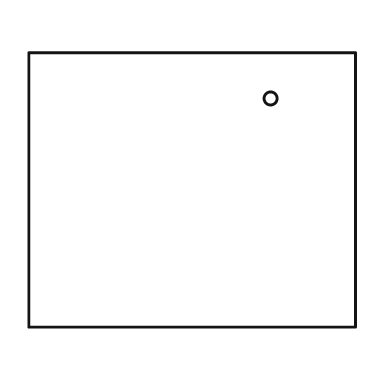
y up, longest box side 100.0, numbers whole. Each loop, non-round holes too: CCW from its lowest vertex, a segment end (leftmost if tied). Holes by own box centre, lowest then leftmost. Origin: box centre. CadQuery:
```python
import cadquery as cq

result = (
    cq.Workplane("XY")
    .moveTo(-50.0, -42.0)
    .lineTo(50.0, -42.0)
    .lineTo(50.0, 42.0)
    .lineTo(-50.0, 42.0)
    .close()
    .moveTo(24.0, 28.0)
    .circle(2.0)
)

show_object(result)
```